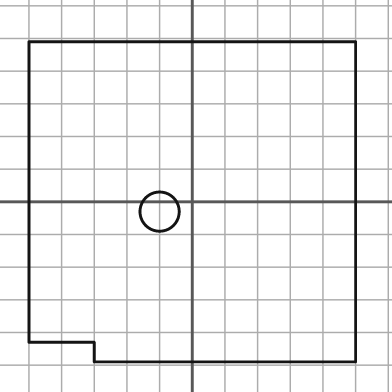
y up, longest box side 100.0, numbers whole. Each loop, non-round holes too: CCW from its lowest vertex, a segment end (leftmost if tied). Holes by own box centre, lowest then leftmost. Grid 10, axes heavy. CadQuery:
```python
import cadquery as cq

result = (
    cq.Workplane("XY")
    .moveTo(-30.0, -49.0)
    .lineTo(50.0, -49.0)
    .lineTo(50.0, 49.0)
    .lineTo(-50.0, 49.0)
    .lineTo(-50.0, -43.0)
    .lineTo(-30.0, -43.0)
    .close()
    .moveTo(-10.0, -3.0)
    .circle(6.0)
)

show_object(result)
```